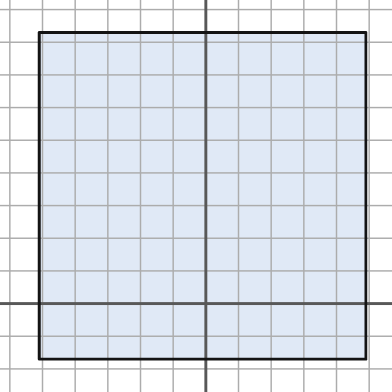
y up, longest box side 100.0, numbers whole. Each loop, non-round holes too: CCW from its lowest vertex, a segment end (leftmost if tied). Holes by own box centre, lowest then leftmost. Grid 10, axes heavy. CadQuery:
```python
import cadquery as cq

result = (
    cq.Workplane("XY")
    .moveTo(-51.0, -17.0)
    .lineTo(49.0, -17.0)
    .lineTo(49.0, 83.0)
    .lineTo(-51.0, 83.0)
    .close()
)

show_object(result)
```